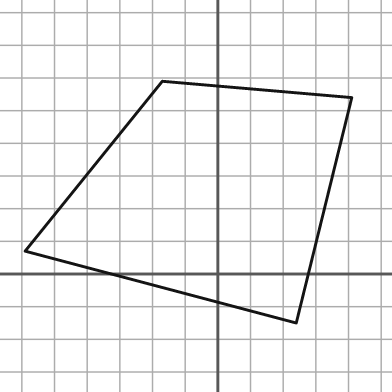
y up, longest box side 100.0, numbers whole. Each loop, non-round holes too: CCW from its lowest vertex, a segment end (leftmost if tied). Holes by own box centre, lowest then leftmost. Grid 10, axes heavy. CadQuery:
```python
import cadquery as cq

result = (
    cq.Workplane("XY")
    .moveTo(24.0, -15.0)
    .lineTo(41.0, 54.0)
    .lineTo(-17.0, 59.0)
    .lineTo(-59.0, 7.0)
    .close()
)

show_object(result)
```